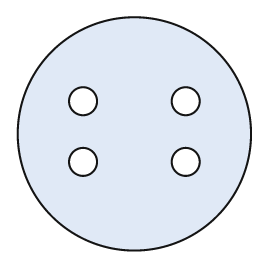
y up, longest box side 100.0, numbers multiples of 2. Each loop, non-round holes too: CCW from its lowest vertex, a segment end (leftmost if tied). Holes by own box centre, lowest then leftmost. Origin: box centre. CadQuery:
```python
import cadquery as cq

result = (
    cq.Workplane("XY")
    .moveTo(0.0, 0.0)
    .circle(50.0)
    .moveTo(-22.0, -12.0)
    .circle(6.0)
    .moveTo(22.0, -12.0)
    .circle(6.0)
    .moveTo(-22.0, 14.0)
    .circle(6.0)
    .moveTo(22.0, 14.0)
    .circle(6.0)
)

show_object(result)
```